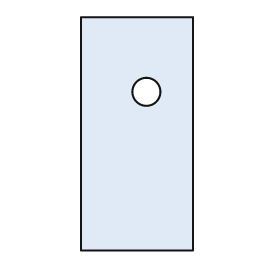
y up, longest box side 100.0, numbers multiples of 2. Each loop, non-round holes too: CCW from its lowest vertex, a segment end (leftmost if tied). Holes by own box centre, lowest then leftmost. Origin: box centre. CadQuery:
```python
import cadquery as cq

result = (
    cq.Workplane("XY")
    .moveTo(-24.0, -50.0)
    .lineTo(24.0, -50.0)
    .lineTo(24.0, 50.0)
    .lineTo(-24.0, 50.0)
    .close()
    .moveTo(4.0, 18.0)
    .circle(6.0)
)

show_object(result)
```